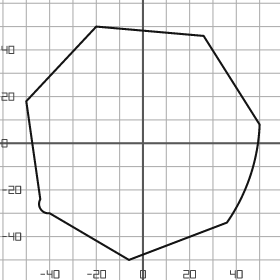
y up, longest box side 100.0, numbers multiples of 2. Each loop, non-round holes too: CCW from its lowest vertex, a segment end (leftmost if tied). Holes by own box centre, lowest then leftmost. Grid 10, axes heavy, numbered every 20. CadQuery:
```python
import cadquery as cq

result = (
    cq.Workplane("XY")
    .moveTo(-6.0, -50.0)
    .lineTo(36.0, -34.0)
    .threePointArc((46.0, -14.0), (50.0, 8.0))
    .lineTo(26.0, 46.0)
    .lineTo(-20.0, 50.0)
    .lineTo(-50.0, 18.0)
    .lineTo(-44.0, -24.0)
    .threePointArc((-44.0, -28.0), (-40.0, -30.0))
    .close()
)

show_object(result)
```